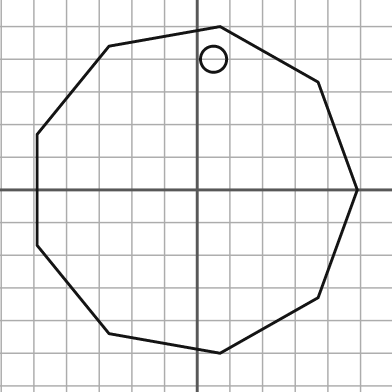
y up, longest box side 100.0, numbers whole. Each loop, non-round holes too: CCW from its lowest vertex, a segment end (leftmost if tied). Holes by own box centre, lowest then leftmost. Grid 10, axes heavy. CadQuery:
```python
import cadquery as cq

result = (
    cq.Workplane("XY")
    .moveTo(7.0, -50.0)
    .lineTo(37.0, -33.0)
    .lineTo(49.0, 0.0)
    .lineTo(37.0, 33.0)
    .lineTo(7.0, 50.0)
    .lineTo(-27.0, 44.0)
    .lineTo(-49.0, 17.0)
    .lineTo(-49.0, -17.0)
    .lineTo(-27.0, -44.0)
    .close()
    .moveTo(5.0, 40.0)
    .circle(4.0)
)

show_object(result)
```